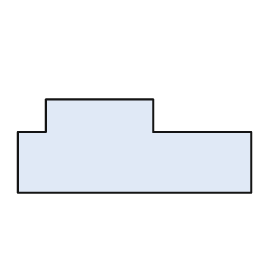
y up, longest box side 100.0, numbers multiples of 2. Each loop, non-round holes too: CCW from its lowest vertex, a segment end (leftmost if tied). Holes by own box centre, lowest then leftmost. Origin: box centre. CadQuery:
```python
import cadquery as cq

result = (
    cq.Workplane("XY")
    .moveTo(-50.0, -20.0)
    .lineTo(50.0, -20.0)
    .lineTo(50.0, 6.0)
    .lineTo(8.0, 6.0)
    .lineTo(8.0, 20.0)
    .lineTo(-38.0, 20.0)
    .lineTo(-38.0, 6.0)
    .lineTo(-50.0, 6.0)
    .close()
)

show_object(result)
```